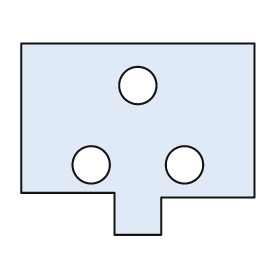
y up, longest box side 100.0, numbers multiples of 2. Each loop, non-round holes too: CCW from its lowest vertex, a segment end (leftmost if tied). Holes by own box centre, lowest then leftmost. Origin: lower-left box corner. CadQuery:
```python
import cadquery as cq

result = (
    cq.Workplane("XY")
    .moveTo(40.0, 0.0)
    .lineTo(60.0, 0.0)
    .lineTo(60.0, 16.0)
    .lineTo(100.0, 16.0)
    .lineTo(100.0, 82.0)
    .lineTo(0.0, 82.0)
    .lineTo(0.0, 18.0)
    .lineTo(40.0, 18.0)
    .close()
    .moveTo(30.0, 30.0)
    .circle(8.0)
    .moveTo(70.0, 30.0)
    .circle(8.0)
    .moveTo(50.0, 64.0)
    .circle(8.0)
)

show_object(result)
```